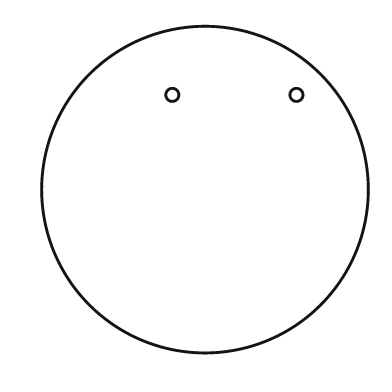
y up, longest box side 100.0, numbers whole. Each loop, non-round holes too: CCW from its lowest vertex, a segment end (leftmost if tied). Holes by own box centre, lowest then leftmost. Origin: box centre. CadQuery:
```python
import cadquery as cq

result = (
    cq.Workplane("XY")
    .moveTo(0.0, 0.0)
    .circle(50.0)
    .moveTo(-10.0, 29.0)
    .circle(2.0)
    .moveTo(28.0, 29.0)
    .circle(2.0)
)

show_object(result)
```